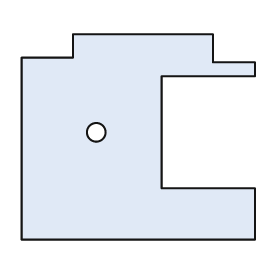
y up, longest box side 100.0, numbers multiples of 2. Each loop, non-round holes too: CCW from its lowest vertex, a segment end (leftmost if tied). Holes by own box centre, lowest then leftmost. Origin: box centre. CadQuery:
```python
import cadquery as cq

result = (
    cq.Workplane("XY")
    .moveTo(-50.0, -44.0)
    .lineTo(50.0, -44.0)
    .lineTo(50.0, -22.0)
    .lineTo(10.0, -22.0)
    .lineTo(10.0, 26.0)
    .lineTo(50.0, 26.0)
    .lineTo(50.0, 32.0)
    .lineTo(32.0, 32.0)
    .lineTo(32.0, 44.0)
    .lineTo(-28.0, 44.0)
    .lineTo(-28.0, 34.0)
    .lineTo(-50.0, 34.0)
    .close()
    .moveTo(-18.0, 2.0)
    .circle(4.0)
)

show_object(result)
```